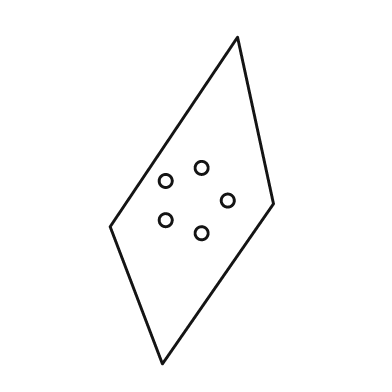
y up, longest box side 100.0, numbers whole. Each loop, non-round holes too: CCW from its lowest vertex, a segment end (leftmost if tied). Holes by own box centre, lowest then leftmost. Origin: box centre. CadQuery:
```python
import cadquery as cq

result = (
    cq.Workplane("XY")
    .moveTo(-9.0, -50.0)
    .lineTo(25.0, -1.0)
    .lineTo(14.0, 50.0)
    .lineTo(-25.0, -8.0)
    .close()
    .moveTo(3.0, -10.0)
    .circle(2.0)
    .moveTo(-8.0, -6.0)
    .circle(2.0)
    .moveTo(11.0, 0.0)
    .circle(2.0)
    .moveTo(-8.0, 6.0)
    .circle(2.0)
    .moveTo(3.0, 10.0)
    .circle(2.0)
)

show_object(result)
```